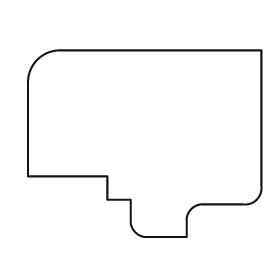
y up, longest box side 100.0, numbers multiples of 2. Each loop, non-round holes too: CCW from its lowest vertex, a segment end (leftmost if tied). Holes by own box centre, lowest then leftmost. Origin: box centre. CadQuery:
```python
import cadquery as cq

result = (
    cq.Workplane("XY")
    .moveTo(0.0, -40.0)
    .lineTo(18.0, -40.0)
    .lineTo(18.0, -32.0)
    .threePointArc((20.0, -28.0), (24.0, -26.0))
    .lineTo(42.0, -26.0)
    .threePointArc((48.0, -24.0), (50.0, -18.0))
    .lineTo(50.0, 40.0)
    .lineTo(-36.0, 40.0)
    .threePointArc((-46.0, 36.0), (-50.0, 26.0))
    .lineTo(-50.0, -14.0)
    .lineTo(-16.0, -14.0)
    .lineTo(-16.0, -24.0)
    .lineTo(-6.0, -24.0)
    .lineTo(-6.0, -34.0)
    .threePointArc((-4.0, -38.0), (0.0, -40.0))
    .close()
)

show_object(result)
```